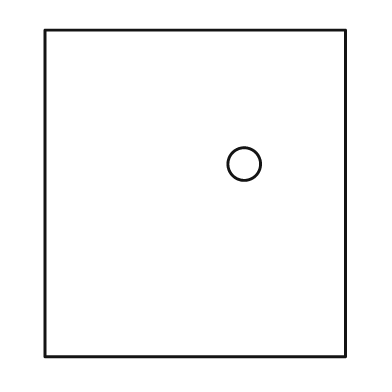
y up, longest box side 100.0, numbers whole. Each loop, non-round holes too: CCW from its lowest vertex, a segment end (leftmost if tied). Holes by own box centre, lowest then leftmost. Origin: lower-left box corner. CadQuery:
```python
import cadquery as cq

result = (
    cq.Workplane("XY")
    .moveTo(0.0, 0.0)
    .lineTo(92.0, 0.0)
    .lineTo(92.0, 100.0)
    .lineTo(0.0, 100.0)
    .close()
    .moveTo(61.0, 59.0)
    .circle(5.0)
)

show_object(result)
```